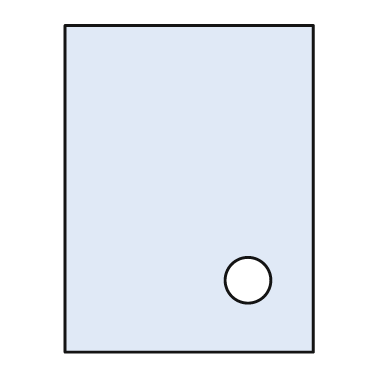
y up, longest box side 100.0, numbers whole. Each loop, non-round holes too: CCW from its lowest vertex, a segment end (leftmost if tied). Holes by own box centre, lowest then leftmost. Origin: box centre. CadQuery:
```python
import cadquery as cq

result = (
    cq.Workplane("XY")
    .moveTo(-38.0, -50.0)
    .lineTo(38.0, -50.0)
    .lineTo(38.0, 50.0)
    .lineTo(-38.0, 50.0)
    .close()
    .moveTo(18.0, -28.0)
    .circle(7.0)
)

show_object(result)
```